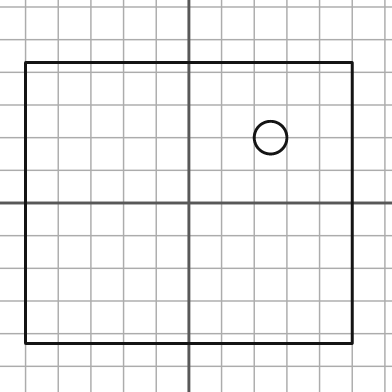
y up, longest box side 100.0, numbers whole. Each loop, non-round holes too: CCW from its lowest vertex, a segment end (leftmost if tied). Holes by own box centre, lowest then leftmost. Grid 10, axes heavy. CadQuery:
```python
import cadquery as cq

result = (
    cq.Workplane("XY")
    .moveTo(-50.0, -43.0)
    .lineTo(50.0, -43.0)
    .lineTo(50.0, 43.0)
    .lineTo(-50.0, 43.0)
    .close()
    .moveTo(25.0, 20.0)
    .circle(5.0)
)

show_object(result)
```